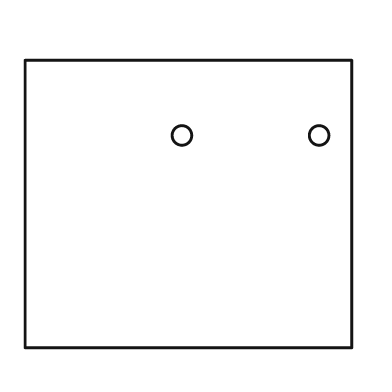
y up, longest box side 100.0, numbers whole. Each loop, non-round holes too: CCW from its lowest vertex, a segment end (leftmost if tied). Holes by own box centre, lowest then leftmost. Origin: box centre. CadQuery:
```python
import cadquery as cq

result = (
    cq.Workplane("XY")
    .moveTo(-50.0, -44.0)
    .lineTo(50.0, -44.0)
    .lineTo(50.0, 44.0)
    .lineTo(-50.0, 44.0)
    .close()
    .moveTo(-2.0, 21.0)
    .circle(3.0)
    .moveTo(40.0, 21.0)
    .circle(3.0)
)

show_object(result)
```